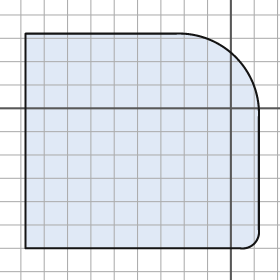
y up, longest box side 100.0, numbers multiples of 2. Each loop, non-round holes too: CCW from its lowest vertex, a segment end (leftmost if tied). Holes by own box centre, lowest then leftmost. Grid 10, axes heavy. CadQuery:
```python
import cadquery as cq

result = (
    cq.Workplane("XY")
    .moveTo(-88.0, -60.0)
    .lineTo(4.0, -60.0)
    .threePointArc((10.0, -58.0), (12.0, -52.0))
    .lineTo(12.0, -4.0)
    .threePointArc((2.0, 22.0), (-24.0, 32.0))
    .lineTo(-88.0, 32.0)
    .close()
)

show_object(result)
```